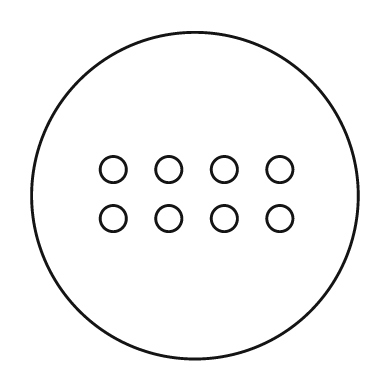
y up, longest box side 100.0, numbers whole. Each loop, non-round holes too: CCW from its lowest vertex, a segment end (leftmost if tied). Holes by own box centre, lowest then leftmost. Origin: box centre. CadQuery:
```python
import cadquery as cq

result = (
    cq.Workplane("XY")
    .moveTo(0.0, 0.0)
    .circle(50.0)
    .moveTo(-25.0, -7.0)
    .circle(4.0)
    .moveTo(-8.0, -7.0)
    .circle(4.0)
    .moveTo(9.0, -7.0)
    .circle(4.0)
    .moveTo(26.0, -7.0)
    .circle(4.0)
    .moveTo(-25.0, 8.0)
    .circle(4.0)
    .moveTo(-8.0, 8.0)
    .circle(4.0)
    .moveTo(9.0, 8.0)
    .circle(4.0)
    .moveTo(26.0, 8.0)
    .circle(4.0)
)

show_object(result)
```